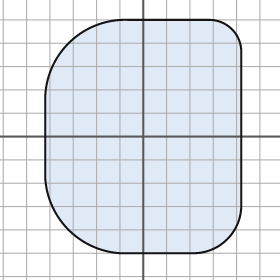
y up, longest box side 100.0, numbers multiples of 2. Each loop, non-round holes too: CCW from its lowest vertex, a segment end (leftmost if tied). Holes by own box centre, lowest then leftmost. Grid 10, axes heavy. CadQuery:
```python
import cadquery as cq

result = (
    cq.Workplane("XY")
    .moveTo(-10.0, -50.0)
    .lineTo(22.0, -50.0)
    .threePointArc((36.0, -44.0), (42.0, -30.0))
    .lineTo(42.0, 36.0)
    .threePointArc((38.0, 46.0), (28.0, 50.0))
    .lineTo(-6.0, 50.0)
    .threePointArc((-32.0, 40.0), (-42.0, 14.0))
    .lineTo(-42.0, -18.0)
    .threePointArc((-32.0, -40.0), (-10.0, -50.0))
    .close()
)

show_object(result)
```